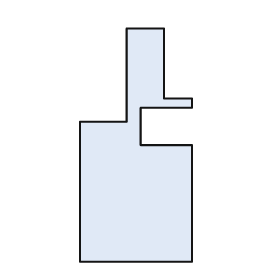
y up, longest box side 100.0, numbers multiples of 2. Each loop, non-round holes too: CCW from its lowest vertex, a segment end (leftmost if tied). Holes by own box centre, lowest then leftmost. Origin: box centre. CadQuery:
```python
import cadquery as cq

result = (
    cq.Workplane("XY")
    .moveTo(-24.0, -50.0)
    .lineTo(24.0, -50.0)
    .lineTo(24.0, 0.0)
    .lineTo(2.0, 0.0)
    .lineTo(2.0, 16.0)
    .lineTo(24.0, 16.0)
    .lineTo(24.0, 20.0)
    .lineTo(12.0, 20.0)
    .lineTo(12.0, 50.0)
    .lineTo(-4.0, 50.0)
    .lineTo(-4.0, 10.0)
    .lineTo(-24.0, 10.0)
    .close()
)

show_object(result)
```